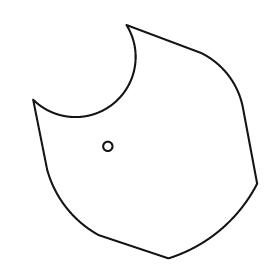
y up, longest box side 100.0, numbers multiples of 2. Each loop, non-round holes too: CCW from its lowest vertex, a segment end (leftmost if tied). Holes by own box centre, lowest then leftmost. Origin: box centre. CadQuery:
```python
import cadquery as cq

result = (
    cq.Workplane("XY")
    .moveTo(10.0, -50.0)
    .threePointArc((32.0, -38.0), (48.0, -18.0))
    .lineTo(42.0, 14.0)
    .threePointArc((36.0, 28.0), (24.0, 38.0))
    .lineTo(-8.0, 50.0)
    .threePointArc((-14.0, 16.0), (-48.0, 18.0))
    .lineTo(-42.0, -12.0)
    .threePointArc((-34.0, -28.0), (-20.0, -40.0))
    .close()
    .moveTo(-16.0, -2.0)
    .circle(2.0)
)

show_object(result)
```